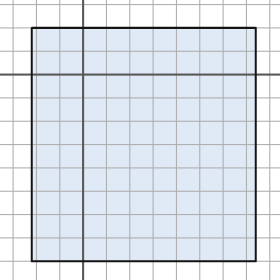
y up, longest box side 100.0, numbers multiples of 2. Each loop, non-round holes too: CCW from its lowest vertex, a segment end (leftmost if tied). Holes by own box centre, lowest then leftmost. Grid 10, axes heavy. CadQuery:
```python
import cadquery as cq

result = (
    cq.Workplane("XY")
    .moveTo(-22.0, -80.0)
    .lineTo(74.0, -80.0)
    .lineTo(74.0, 20.0)
    .lineTo(-22.0, 20.0)
    .close()
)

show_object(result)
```